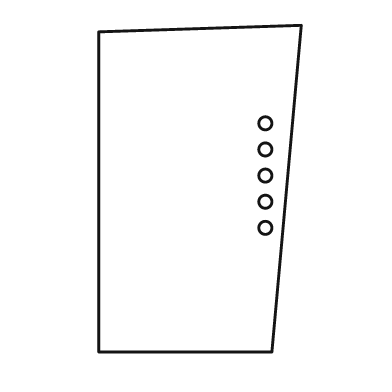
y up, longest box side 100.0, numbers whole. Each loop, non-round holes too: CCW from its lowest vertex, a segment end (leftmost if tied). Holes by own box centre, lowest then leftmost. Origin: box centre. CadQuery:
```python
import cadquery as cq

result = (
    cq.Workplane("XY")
    .moveTo(-31.0, -50.0)
    .lineTo(22.0, -50.0)
    .lineTo(31.0, 50.0)
    .lineTo(-31.0, 48.0)
    .close()
    .moveTo(20.0, -12.0)
    .circle(2.0)
    .moveTo(20.0, -4.0)
    .circle(2.0)
    .moveTo(20.0, 4.0)
    .circle(2.0)
    .moveTo(20.0, 12.0)
    .circle(2.0)
    .moveTo(20.0, 20.0)
    .circle(2.0)
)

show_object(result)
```